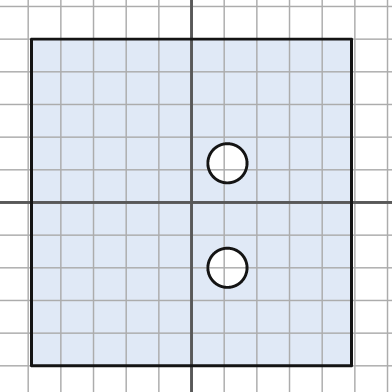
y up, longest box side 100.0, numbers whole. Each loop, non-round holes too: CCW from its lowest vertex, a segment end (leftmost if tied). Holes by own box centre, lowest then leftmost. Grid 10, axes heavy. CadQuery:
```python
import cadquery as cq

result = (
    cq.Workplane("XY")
    .moveTo(-49.0, -50.0)
    .lineTo(49.0, -50.0)
    .lineTo(49.0, 50.0)
    .lineTo(-49.0, 50.0)
    .close()
    .moveTo(11.0, -20.0)
    .circle(6.0)
    .moveTo(11.0, 12.0)
    .circle(6.0)
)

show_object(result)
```